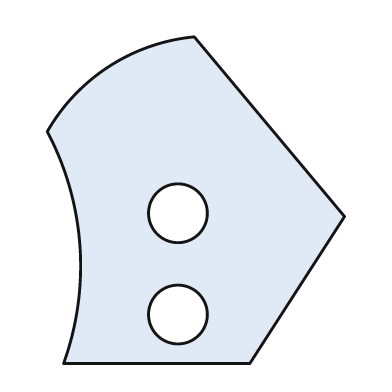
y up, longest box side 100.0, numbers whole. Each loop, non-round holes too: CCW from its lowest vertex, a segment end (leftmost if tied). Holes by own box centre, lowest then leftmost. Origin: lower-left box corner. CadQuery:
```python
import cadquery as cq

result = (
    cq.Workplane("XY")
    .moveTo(5.0, 0.0)
    .lineTo(62.0, 0.0)
    .lineTo(91.0, 45.0)
    .lineTo(45.0, 100.0)
    .threePointArc((19.0, 91.0), (0.0, 71.0))
    .threePointArc((10.0, 36.0), (5.0, 0.0))
    .close()
    .moveTo(40.0, 15.0)
    .circle(9.0)
    .moveTo(40.0, 46.0)
    .circle(9.0)
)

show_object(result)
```